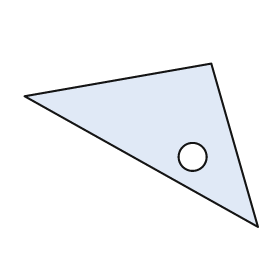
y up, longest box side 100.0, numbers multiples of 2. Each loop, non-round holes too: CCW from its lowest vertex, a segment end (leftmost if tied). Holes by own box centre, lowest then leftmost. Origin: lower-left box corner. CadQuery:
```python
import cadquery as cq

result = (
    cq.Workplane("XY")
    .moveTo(100.0, 0.0)
    .lineTo(80.0, 70.0)
    .lineTo(0.0, 56.0)
    .close()
    .moveTo(72.0, 30.0)
    .circle(6.0)
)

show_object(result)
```